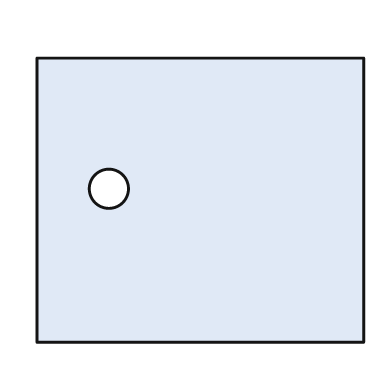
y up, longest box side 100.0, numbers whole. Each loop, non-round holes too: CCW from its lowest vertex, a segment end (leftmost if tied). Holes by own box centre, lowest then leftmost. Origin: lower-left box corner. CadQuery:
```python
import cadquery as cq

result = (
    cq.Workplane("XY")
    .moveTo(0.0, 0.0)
    .lineTo(100.0, 0.0)
    .lineTo(100.0, 87.0)
    .lineTo(0.0, 87.0)
    .close()
    .moveTo(22.0, 47.0)
    .circle(6.0)
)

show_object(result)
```